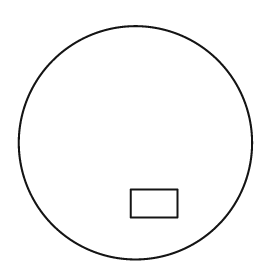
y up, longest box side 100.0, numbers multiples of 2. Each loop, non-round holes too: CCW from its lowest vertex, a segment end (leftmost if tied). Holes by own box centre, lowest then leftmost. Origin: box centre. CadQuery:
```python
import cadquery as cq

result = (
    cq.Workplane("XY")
    .moveTo(0.0, 0.0)
    .circle(50.0)
    .moveTo(-2.0, -32.0)
    .lineTo(18.0, -32.0)
    .lineTo(18.0, -20.0)
    .lineTo(-2.0, -20.0)
    .close()
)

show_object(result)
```